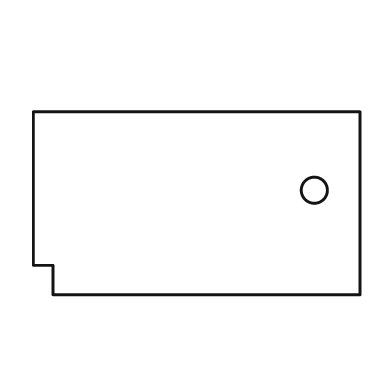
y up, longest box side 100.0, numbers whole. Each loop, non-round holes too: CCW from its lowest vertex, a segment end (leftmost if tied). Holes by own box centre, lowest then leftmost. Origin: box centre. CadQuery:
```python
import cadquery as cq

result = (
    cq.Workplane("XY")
    .moveTo(-44.0, -28.0)
    .lineTo(50.0, -28.0)
    .lineTo(50.0, 28.0)
    .lineTo(-50.0, 28.0)
    .lineTo(-50.0, -19.0)
    .lineTo(-44.0, -19.0)
    .close()
    .moveTo(36.0, 4.0)
    .circle(4.0)
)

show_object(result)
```